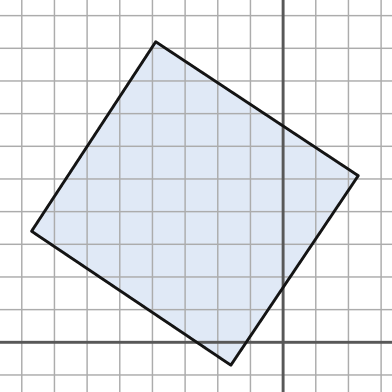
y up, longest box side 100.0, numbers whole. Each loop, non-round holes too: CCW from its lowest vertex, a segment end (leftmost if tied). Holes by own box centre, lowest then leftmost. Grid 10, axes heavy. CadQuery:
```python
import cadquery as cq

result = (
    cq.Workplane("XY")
    .moveTo(-16.0, -7.0)
    .lineTo(23.0, 51.0)
    .lineTo(-39.0, 92.0)
    .lineTo(-77.0, 34.0)
    .close()
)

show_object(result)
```